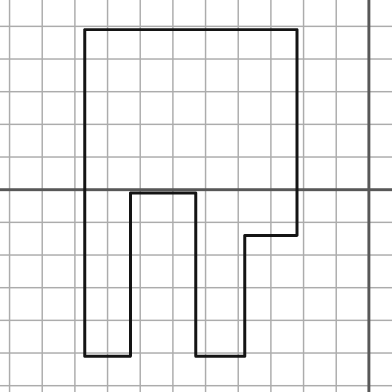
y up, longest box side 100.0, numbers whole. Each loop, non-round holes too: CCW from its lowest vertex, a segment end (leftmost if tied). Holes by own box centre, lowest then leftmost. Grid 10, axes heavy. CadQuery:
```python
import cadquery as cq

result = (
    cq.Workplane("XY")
    .moveTo(-87.0, -51.0)
    .lineTo(-73.0, -51.0)
    .lineTo(-73.0, -1.0)
    .lineTo(-53.0, -1.0)
    .lineTo(-53.0, -51.0)
    .lineTo(-38.0, -51.0)
    .lineTo(-38.0, -14.0)
    .lineTo(-22.0, -14.0)
    .lineTo(-22.0, 49.0)
    .lineTo(-87.0, 49.0)
    .close()
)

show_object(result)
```